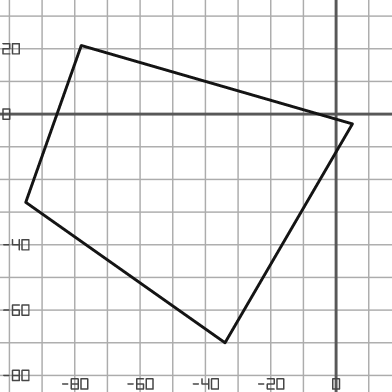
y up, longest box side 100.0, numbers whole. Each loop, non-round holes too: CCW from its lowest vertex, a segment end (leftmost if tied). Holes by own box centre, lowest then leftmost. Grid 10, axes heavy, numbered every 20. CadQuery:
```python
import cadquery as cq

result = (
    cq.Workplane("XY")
    .moveTo(-34.0, -70.0)
    .lineTo(5.0, -3.0)
    .lineTo(-78.0, 21.0)
    .lineTo(-95.0, -27.0)
    .close()
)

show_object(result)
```